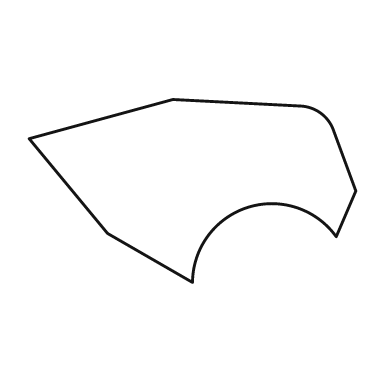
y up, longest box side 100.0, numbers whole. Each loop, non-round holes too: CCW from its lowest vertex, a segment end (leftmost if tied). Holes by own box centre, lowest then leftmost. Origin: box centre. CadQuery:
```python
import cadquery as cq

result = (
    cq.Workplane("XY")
    .moveTo(0.0, -28.0)
    .threePointArc((17.0, -5.0), (44.0, -14.0))
    .lineTo(50.0, 0.0)
    .lineTo(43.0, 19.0)
    .threePointArc((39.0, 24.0), (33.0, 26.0))
    .lineTo(-6.0, 28.0)
    .lineTo(-50.0, 16.0)
    .lineTo(-26.0, -13.0)
    .close()
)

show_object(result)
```